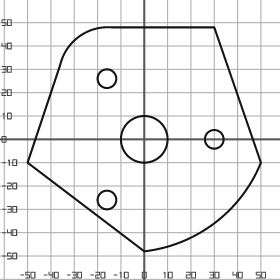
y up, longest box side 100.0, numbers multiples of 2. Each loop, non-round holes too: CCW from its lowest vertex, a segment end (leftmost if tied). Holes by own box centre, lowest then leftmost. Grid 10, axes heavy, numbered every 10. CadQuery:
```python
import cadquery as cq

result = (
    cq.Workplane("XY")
    .moveTo(0.0, -48.0)
    .threePointArc((30.0, -36.0), (50.0, -10.0))
    .lineTo(30.0, 48.0)
    .lineTo(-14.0, 48.0)
    .threePointArc((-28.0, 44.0), (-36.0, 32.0))
    .lineTo(-50.0, -10.0)
    .close()
    .moveTo(-16.0, -26.0)
    .circle(4.0)
    .moveTo(0.0, 0.0)
    .circle(10.0)
    .moveTo(30.0, 0.0)
    .circle(4.0)
    .moveTo(-16.0, 26.0)
    .circle(4.0)
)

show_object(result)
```